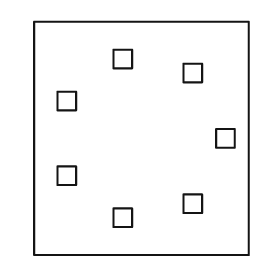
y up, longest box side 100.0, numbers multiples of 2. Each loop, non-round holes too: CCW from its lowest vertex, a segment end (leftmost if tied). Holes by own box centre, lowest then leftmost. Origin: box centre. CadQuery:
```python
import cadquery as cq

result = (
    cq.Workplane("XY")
    .moveTo(-46.0, -50.0)
    .lineTo(46.0, -50.0)
    .lineTo(46.0, 50.0)
    .lineTo(-46.0, 50.0)
    .close()
    .moveTo(-12.0, -38.0)
    .lineTo(-4.0, -38.0)
    .lineTo(-4.0, -30.0)
    .lineTo(-12.0, -30.0)
    .close()
    .moveTo(18.0, -32.0)
    .lineTo(26.0, -32.0)
    .lineTo(26.0, -24.0)
    .lineTo(18.0, -24.0)
    .close()
    .moveTo(-36.0, -20.0)
    .lineTo(-28.0, -20.0)
    .lineTo(-28.0, -12.0)
    .lineTo(-36.0, -12.0)
    .close()
    .moveTo(32.0, -4.0)
    .lineTo(40.0, -4.0)
    .lineTo(40.0, 4.0)
    .lineTo(32.0, 4.0)
    .close()
    .moveTo(-36.0, 12.0)
    .lineTo(-28.0, 12.0)
    .lineTo(-28.0, 20.0)
    .lineTo(-36.0, 20.0)
    .close()
    .moveTo(18.0, 24.0)
    .lineTo(26.0, 24.0)
    .lineTo(26.0, 32.0)
    .lineTo(18.0, 32.0)
    .close()
    .moveTo(-12.0, 30.0)
    .lineTo(-4.0, 30.0)
    .lineTo(-4.0, 38.0)
    .lineTo(-12.0, 38.0)
    .close()
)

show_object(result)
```